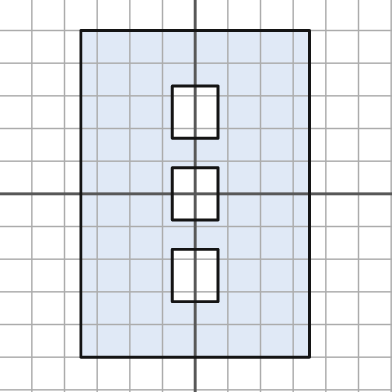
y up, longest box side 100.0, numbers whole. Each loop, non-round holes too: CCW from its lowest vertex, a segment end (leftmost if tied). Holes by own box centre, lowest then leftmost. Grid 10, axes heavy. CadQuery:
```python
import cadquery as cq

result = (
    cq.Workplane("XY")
    .moveTo(-35.0, -50.0)
    .lineTo(35.0, -50.0)
    .lineTo(35.0, 50.0)
    .lineTo(-35.0, 50.0)
    .close()
    .moveTo(-7.0, -33.0)
    .lineTo(7.0, -33.0)
    .lineTo(7.0, -17.0)
    .lineTo(-7.0, -17.0)
    .close()
    .moveTo(-7.0, -8.0)
    .lineTo(7.0, -8.0)
    .lineTo(7.0, 8.0)
    .lineTo(-7.0, 8.0)
    .close()
    .moveTo(-7.0, 17.0)
    .lineTo(7.0, 17.0)
    .lineTo(7.0, 33.0)
    .lineTo(-7.0, 33.0)
    .close()
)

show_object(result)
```